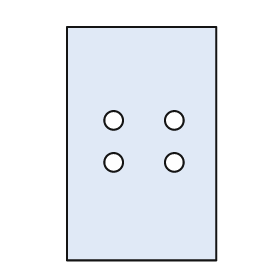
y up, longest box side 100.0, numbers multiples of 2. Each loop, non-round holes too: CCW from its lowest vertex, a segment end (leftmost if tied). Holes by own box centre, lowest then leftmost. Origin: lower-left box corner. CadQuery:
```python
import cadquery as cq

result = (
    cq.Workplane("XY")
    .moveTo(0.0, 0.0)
    .lineTo(64.0, 0.0)
    .lineTo(64.0, 100.0)
    .lineTo(0.0, 100.0)
    .close()
    .moveTo(20.0, 42.0)
    .circle(4.0)
    .moveTo(46.0, 42.0)
    .circle(4.0)
    .moveTo(20.0, 60.0)
    .circle(4.0)
    .moveTo(46.0, 60.0)
    .circle(4.0)
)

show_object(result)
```